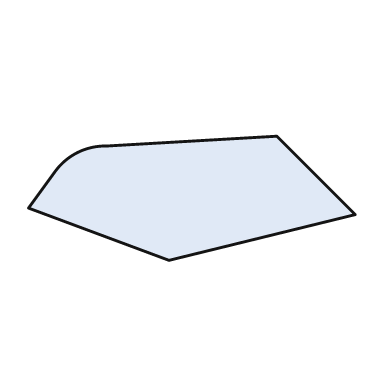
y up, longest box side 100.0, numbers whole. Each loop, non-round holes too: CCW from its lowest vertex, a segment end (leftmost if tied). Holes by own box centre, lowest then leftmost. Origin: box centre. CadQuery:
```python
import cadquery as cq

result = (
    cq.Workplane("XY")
    .moveTo(-7.0, -19.0)
    .lineTo(50.0, -5.0)
    .lineTo(26.0, 19.0)
    .lineTo(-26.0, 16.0)
    .threePointArc((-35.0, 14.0), (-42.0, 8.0))
    .lineTo(-50.0, -3.0)
    .close()
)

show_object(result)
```